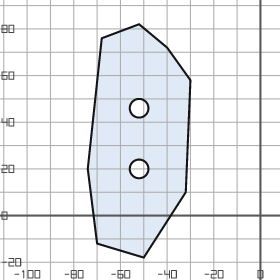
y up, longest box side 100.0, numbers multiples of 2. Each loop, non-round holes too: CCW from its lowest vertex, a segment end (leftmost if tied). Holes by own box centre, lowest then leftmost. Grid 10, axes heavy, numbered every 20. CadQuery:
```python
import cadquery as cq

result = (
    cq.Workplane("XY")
    .moveTo(-50.0, -18.0)
    .lineTo(-32.0, 10.0)
    .lineTo(-30.0, 58.0)
    .lineTo(-40.0, 72.0)
    .lineTo(-52.0, 82.0)
    .lineTo(-68.0, 76.0)
    .lineTo(-74.0, 20.0)
    .lineTo(-70.0, -12.0)
    .close()
    .moveTo(-52.0, 20.0)
    .circle(4.0)
    .moveTo(-52.0, 46.0)
    .circle(4.0)
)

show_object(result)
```